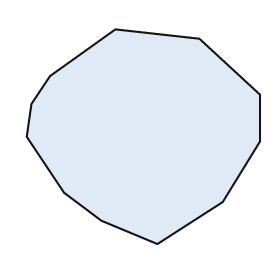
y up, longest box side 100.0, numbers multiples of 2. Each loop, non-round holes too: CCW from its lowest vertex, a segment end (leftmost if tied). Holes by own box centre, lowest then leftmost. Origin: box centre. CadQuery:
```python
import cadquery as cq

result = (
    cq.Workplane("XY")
    .moveTo(6.0, -46.0)
    .lineTo(34.0, -28.0)
    .lineTo(50.0, -2.0)
    .lineTo(50.0, 18.0)
    .lineTo(24.0, 42.0)
    .lineTo(-12.0, 46.0)
    .lineTo(-40.0, 26.0)
    .lineTo(-48.0, 14.0)
    .lineTo(-50.0, 0.0)
    .lineTo(-34.0, -24.0)
    .lineTo(-18.0, -36.0)
    .close()
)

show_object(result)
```